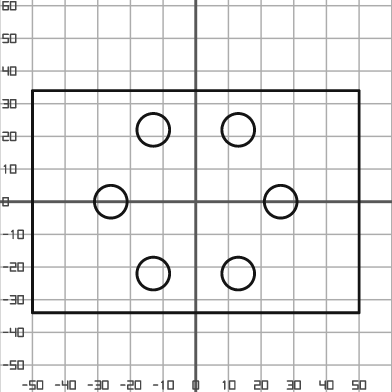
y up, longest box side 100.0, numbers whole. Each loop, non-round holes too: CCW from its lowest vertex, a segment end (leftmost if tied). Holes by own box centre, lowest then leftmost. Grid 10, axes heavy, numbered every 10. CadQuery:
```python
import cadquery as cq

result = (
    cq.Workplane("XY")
    .moveTo(-50.0, -34.0)
    .lineTo(50.0, -34.0)
    .lineTo(50.0, 34.0)
    .lineTo(-50.0, 34.0)
    .close()
    .moveTo(-13.0, -22.0)
    .circle(5.0)
    .moveTo(13.0, -22.0)
    .circle(5.0)
    .moveTo(-26.0, 0.0)
    .circle(5.0)
    .moveTo(26.0, 0.0)
    .circle(5.0)
    .moveTo(-13.0, 22.0)
    .circle(5.0)
    .moveTo(13.0, 22.0)
    .circle(5.0)
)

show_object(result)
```